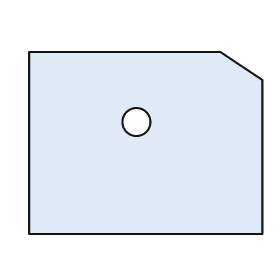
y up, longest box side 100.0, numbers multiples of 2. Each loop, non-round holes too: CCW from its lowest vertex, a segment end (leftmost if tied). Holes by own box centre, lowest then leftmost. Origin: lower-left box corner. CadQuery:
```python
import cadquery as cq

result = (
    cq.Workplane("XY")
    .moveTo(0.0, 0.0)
    .lineTo(100.0, 0.0)
    .lineTo(100.0, 66.0)
    .lineTo(82.0, 78.0)
    .lineTo(0.0, 78.0)
    .close()
    .moveTo(46.0, 48.0)
    .circle(6.0)
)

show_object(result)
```